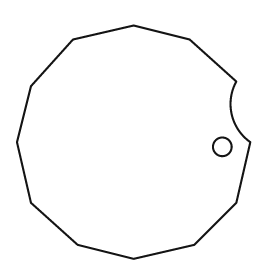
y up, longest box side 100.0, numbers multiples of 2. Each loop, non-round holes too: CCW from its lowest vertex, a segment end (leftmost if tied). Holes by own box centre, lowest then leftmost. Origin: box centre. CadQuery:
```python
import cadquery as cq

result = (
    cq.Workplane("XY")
    .moveTo(0.0, -50.0)
    .lineTo(26.0, -44.0)
    .lineTo(44.0, -26.0)
    .lineTo(50.0, 0.0)
    .threePointArc((42.0, 12.0), (44.0, 26.0))
    .lineTo(24.0, 44.0)
    .lineTo(0.0, 50.0)
    .lineTo(-26.0, 44.0)
    .lineTo(-44.0, 24.0)
    .lineTo(-50.0, 0.0)
    .lineTo(-44.0, -26.0)
    .lineTo(-24.0, -44.0)
    .close()
    .moveTo(38.0, -2.0)
    .circle(4.0)
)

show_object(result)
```